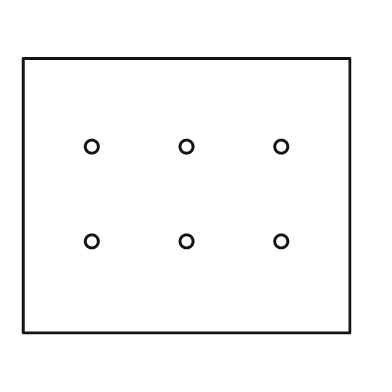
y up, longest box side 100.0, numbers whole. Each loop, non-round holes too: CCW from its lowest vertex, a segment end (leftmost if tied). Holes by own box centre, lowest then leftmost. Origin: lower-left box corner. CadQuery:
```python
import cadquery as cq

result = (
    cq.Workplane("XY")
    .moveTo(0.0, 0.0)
    .lineTo(100.0, 0.0)
    .lineTo(100.0, 84.0)
    .lineTo(0.0, 84.0)
    .close()
    .moveTo(21.0, 28.0)
    .circle(2.0)
    .moveTo(50.0, 28.0)
    .circle(2.0)
    .moveTo(79.0, 28.0)
    .circle(2.0)
    .moveTo(21.0, 57.0)
    .circle(2.0)
    .moveTo(50.0, 57.0)
    .circle(2.0)
    .moveTo(79.0, 57.0)
    .circle(2.0)
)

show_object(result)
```